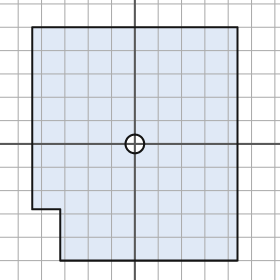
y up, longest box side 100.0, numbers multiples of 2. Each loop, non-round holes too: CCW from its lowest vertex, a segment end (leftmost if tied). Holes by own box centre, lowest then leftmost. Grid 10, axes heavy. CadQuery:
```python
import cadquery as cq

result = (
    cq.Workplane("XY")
    .moveTo(-32.0, -50.0)
    .lineTo(44.0, -50.0)
    .lineTo(44.0, 50.0)
    .lineTo(-44.0, 50.0)
    .lineTo(-44.0, -28.0)
    .lineTo(-32.0, -28.0)
    .close()
    .moveTo(0.0, 0.0)
    .circle(4.0)
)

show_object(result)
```